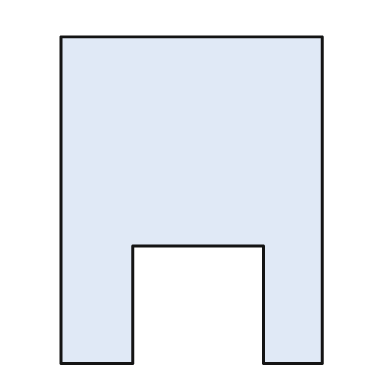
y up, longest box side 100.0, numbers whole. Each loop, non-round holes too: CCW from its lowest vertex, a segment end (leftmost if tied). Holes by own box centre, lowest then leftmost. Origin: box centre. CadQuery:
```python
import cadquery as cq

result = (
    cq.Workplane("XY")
    .moveTo(-40.0, -50.0)
    .lineTo(-18.0, -50.0)
    .lineTo(-18.0, -14.0)
    .lineTo(22.0, -14.0)
    .lineTo(22.0, -50.0)
    .lineTo(40.0, -50.0)
    .lineTo(40.0, 50.0)
    .lineTo(-40.0, 50.0)
    .close()
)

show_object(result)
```